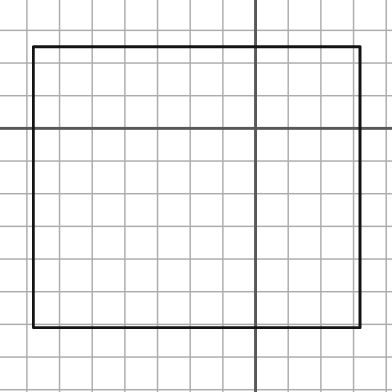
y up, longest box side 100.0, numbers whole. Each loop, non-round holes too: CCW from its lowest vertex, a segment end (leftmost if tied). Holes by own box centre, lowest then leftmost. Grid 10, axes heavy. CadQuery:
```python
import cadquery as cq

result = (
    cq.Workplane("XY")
    .moveTo(-68.0, -61.0)
    .lineTo(32.0, -61.0)
    .lineTo(32.0, 25.0)
    .lineTo(-68.0, 25.0)
    .close()
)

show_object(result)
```